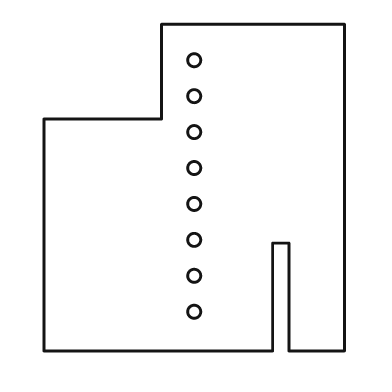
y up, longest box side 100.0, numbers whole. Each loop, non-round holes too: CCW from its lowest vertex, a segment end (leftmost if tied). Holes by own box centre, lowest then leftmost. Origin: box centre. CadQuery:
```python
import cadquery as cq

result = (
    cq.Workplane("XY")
    .moveTo(-46.0, -50.0)
    .lineTo(24.0, -50.0)
    .lineTo(24.0, -17.0)
    .lineTo(29.0, -17.0)
    .lineTo(29.0, -50.0)
    .lineTo(46.0, -50.0)
    .lineTo(46.0, 50.0)
    .lineTo(-10.0, 50.0)
    .lineTo(-10.0, 21.0)
    .lineTo(-46.0, 21.0)
    .close()
    .moveTo(0.0, -38.0)
    .circle(2.0)
    .moveTo(0.0, -27.0)
    .circle(2.0)
    .moveTo(0.0, -16.0)
    .circle(2.0)
    .moveTo(0.0, -5.0)
    .circle(2.0)
    .moveTo(0.0, 6.0)
    .circle(2.0)
    .moveTo(0.0, 17.0)
    .circle(2.0)
    .moveTo(0.0, 28.0)
    .circle(2.0)
    .moveTo(0.0, 39.0)
    .circle(2.0)
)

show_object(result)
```